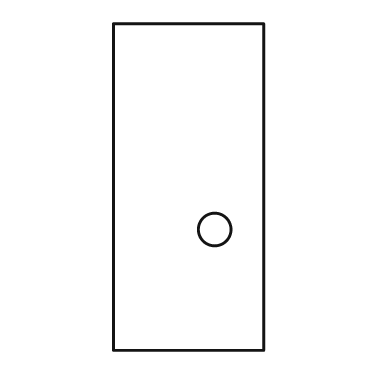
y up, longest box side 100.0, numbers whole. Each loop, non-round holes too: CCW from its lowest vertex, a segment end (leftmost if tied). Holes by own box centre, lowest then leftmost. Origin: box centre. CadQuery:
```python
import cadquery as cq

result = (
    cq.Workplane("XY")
    .moveTo(-23.0, -50.0)
    .lineTo(23.0, -50.0)
    .lineTo(23.0, 50.0)
    .lineTo(-23.0, 50.0)
    .close()
    .moveTo(8.0, -13.0)
    .circle(5.0)
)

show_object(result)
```